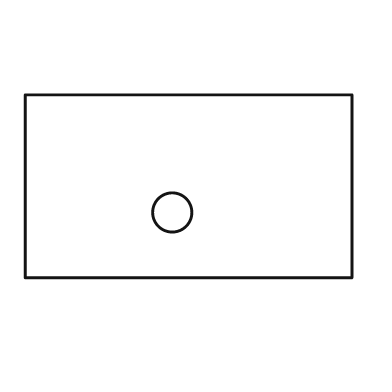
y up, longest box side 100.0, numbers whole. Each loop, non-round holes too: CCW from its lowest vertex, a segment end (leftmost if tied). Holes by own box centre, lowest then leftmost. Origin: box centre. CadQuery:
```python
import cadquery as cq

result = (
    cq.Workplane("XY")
    .moveTo(-50.0, -28.0)
    .lineTo(50.0, -28.0)
    .lineTo(50.0, 28.0)
    .lineTo(-50.0, 28.0)
    .close()
    .moveTo(-5.0, -8.0)
    .circle(6.0)
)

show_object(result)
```